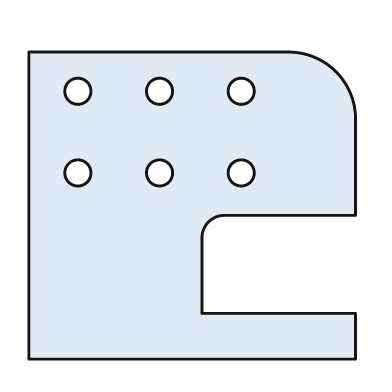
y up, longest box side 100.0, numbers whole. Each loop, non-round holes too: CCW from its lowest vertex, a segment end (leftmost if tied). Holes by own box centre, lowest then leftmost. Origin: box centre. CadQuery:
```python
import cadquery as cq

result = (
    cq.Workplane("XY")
    .moveTo(-50.0, -47.0)
    .lineTo(50.0, -47.0)
    .lineTo(50.0, -33.0)
    .lineTo(3.0, -33.0)
    .lineTo(3.0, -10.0)
    .threePointArc((5.0, -5.0), (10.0, -3.0))
    .lineTo(50.0, -3.0)
    .lineTo(50.0, 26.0)
    .threePointArc((44.0, 41.0), (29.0, 47.0))
    .lineTo(-50.0, 47.0)
    .close()
    .moveTo(-35.0, 10.0)
    .circle(4.0)
    .moveTo(-10.0, 10.0)
    .circle(4.0)
    .moveTo(15.0, 10.0)
    .circle(4.0)
    .moveTo(-35.0, 35.0)
    .circle(4.0)
    .moveTo(-10.0, 35.0)
    .circle(4.0)
    .moveTo(15.0, 35.0)
    .circle(4.0)
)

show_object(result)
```